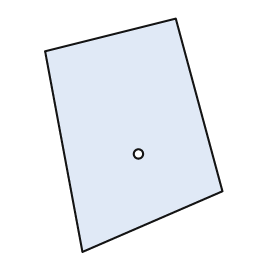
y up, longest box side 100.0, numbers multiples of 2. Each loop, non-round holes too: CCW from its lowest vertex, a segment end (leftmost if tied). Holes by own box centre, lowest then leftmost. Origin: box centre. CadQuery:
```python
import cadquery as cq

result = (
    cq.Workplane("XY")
    .moveTo(-22.0, -50.0)
    .lineTo(38.0, -24.0)
    .lineTo(18.0, 50.0)
    .lineTo(-38.0, 36.0)
    .close()
    .moveTo(2.0, -8.0)
    .circle(2.0)
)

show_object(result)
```